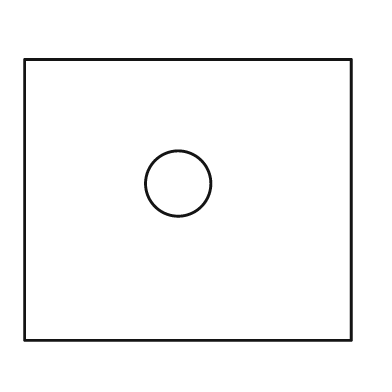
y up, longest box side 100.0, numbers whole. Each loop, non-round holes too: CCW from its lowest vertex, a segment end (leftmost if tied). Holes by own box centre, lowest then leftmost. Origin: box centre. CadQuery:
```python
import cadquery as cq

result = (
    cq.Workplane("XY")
    .moveTo(-50.0, -43.0)
    .lineTo(50.0, -43.0)
    .lineTo(50.0, 43.0)
    .lineTo(-50.0, 43.0)
    .close()
    .moveTo(-3.0, 5.0)
    .circle(10.0)
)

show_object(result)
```